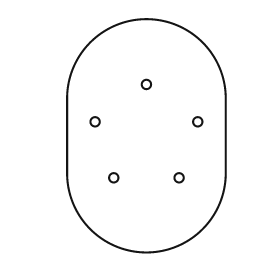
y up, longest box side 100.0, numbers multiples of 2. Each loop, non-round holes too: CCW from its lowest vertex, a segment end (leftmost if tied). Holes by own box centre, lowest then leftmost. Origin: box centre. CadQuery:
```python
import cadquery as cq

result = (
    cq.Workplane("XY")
    .moveTo(-34.0, -16.0)
    .threePointArc((0.0, -50.0), (34.0, -16.0))
    .lineTo(34.0, 16.0)
    .threePointArc((0.0, 50.0), (-34.0, 16.0))
    .close()
    .moveTo(-14.0, -18.0)
    .circle(2.0)
    .moveTo(14.0, -18.0)
    .circle(2.0)
    .moveTo(-22.0, 6.0)
    .circle(2.0)
    .moveTo(22.0, 6.0)
    .circle(2.0)
    .moveTo(0.0, 22.0)
    .circle(2.0)
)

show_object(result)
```